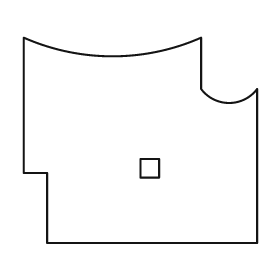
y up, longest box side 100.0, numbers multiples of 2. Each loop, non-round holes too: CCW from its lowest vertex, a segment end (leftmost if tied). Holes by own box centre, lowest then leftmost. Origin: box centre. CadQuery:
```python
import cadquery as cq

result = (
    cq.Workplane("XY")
    .moveTo(-40.0, -44.0)
    .lineTo(50.0, -44.0)
    .lineTo(50.0, 22.0)
    .threePointArc((38.0, 16.0), (26.0, 22.0))
    .lineTo(26.0, 44.0)
    .threePointArc((-12.0, 36.0), (-50.0, 44.0))
    .lineTo(-50.0, -14.0)
    .lineTo(-40.0, -14.0)
    .close()
    .moveTo(0.0, -16.0)
    .lineTo(8.0, -16.0)
    .lineTo(8.0, -8.0)
    .lineTo(0.0, -8.0)
    .close()
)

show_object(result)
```